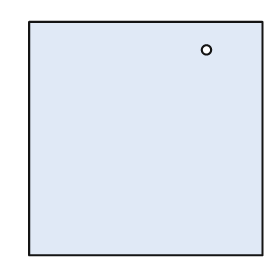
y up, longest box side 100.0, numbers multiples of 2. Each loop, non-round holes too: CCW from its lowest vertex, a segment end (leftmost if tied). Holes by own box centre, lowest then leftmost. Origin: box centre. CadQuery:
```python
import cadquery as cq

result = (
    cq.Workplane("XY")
    .moveTo(-50.0, -50.0)
    .lineTo(50.0, -50.0)
    .lineTo(50.0, 50.0)
    .lineTo(-50.0, 50.0)
    .close()
    .moveTo(26.0, 38.0)
    .circle(2.0)
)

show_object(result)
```